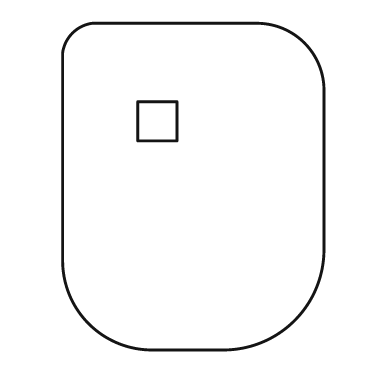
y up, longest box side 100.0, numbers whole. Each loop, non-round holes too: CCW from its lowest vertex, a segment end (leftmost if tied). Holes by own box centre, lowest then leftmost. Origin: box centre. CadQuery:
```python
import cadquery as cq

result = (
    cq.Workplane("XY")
    .moveTo(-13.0, -50.0)
    .lineTo(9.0, -50.0)
    .threePointArc((31.0, -41.0), (40.0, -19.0))
    .lineTo(40.0, 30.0)
    .threePointArc((34.0, 44.0), (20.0, 50.0))
    .lineTo(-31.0, 50.0)
    .threePointArc((-37.0, 47.0), (-40.0, 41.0))
    .lineTo(-40.0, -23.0)
    .threePointArc((-32.0, -42.0), (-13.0, -50.0))
    .close()
    .moveTo(-17.0, 14.0)
    .lineTo(-5.0, 14.0)
    .lineTo(-5.0, 26.0)
    .lineTo(-17.0, 26.0)
    .close()
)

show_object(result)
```